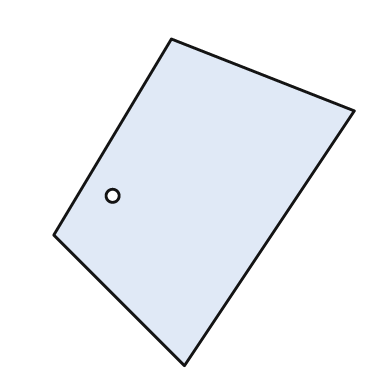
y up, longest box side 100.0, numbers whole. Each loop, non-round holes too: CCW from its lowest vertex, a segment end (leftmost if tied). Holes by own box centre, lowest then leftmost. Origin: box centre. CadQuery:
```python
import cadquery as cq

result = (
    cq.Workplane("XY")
    .moveTo(-6.0, -50.0)
    .lineTo(46.0, 28.0)
    .lineTo(-10.0, 50.0)
    .lineTo(-46.0, -10.0)
    .close()
    .moveTo(-28.0, 2.0)
    .circle(2.0)
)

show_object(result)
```